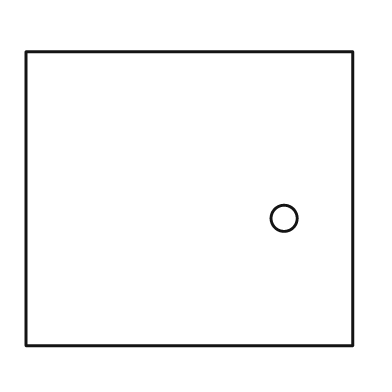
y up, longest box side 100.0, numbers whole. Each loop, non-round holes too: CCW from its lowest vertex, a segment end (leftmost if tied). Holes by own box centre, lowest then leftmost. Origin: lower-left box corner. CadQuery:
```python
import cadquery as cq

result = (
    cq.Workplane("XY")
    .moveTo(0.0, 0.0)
    .lineTo(100.0, 0.0)
    .lineTo(100.0, 90.0)
    .lineTo(0.0, 90.0)
    .close()
    .moveTo(79.0, 39.0)
    .circle(4.0)
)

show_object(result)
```